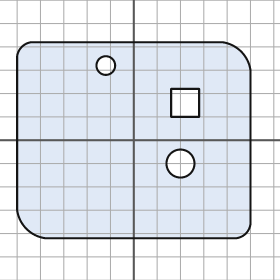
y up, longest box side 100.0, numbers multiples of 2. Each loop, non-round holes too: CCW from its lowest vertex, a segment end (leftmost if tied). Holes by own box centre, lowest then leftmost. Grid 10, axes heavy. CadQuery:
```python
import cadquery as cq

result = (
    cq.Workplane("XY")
    .moveTo(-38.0, -42.0)
    .lineTo(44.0, -42.0)
    .threePointArc((48.0, -40.0), (50.0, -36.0))
    .lineTo(50.0, 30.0)
    .threePointArc((46.0, 38.0), (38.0, 42.0))
    .lineTo(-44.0, 42.0)
    .threePointArc((-48.0, 40.0), (-50.0, 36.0))
    .lineTo(-50.0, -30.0)
    .threePointArc((-46.0, -38.0), (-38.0, -42.0))
    .close()
    .moveTo(20.0, -10.0)
    .circle(6.0)
    .moveTo(16.0, 10.0)
    .lineTo(28.0, 10.0)
    .lineTo(28.0, 22.0)
    .lineTo(16.0, 22.0)
    .close()
    .moveTo(-12.0, 32.0)
    .circle(4.0)
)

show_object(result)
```